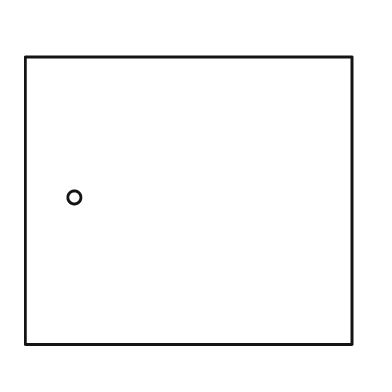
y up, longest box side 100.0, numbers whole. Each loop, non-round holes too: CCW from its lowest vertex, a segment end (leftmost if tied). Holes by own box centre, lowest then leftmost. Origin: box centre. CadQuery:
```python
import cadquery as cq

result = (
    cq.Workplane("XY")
    .moveTo(-50.0, -44.0)
    .lineTo(50.0, -44.0)
    .lineTo(50.0, 44.0)
    .lineTo(-50.0, 44.0)
    .close()
    .moveTo(-35.0, 1.0)
    .circle(2.0)
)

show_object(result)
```